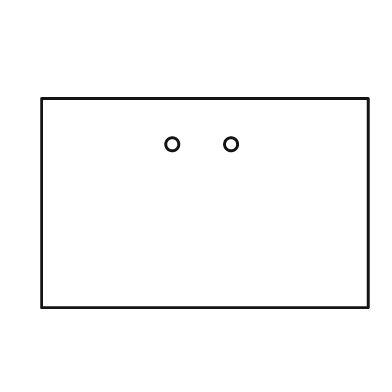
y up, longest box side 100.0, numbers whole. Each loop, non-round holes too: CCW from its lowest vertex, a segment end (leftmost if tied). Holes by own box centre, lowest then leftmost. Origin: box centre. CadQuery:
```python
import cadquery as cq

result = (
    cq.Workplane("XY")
    .moveTo(-50.0, -32.0)
    .lineTo(50.0, -32.0)
    .lineTo(50.0, 32.0)
    .lineTo(-50.0, 32.0)
    .close()
    .moveTo(-10.0, 18.0)
    .circle(2.0)
    .moveTo(8.0, 18.0)
    .circle(2.0)
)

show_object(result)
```